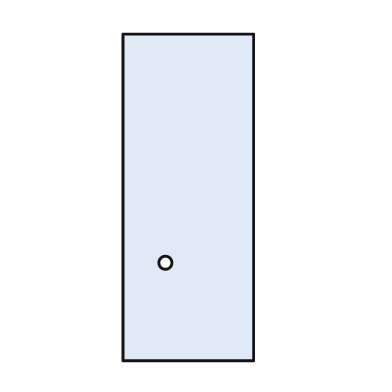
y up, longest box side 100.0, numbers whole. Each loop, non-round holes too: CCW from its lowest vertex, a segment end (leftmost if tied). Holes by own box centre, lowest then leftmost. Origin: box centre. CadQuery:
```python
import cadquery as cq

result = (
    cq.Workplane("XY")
    .moveTo(-20.0, -50.0)
    .lineTo(20.0, -50.0)
    .lineTo(20.0, 50.0)
    .lineTo(-20.0, 50.0)
    .close()
    .moveTo(-7.0, -20.0)
    .circle(2.0)
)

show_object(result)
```